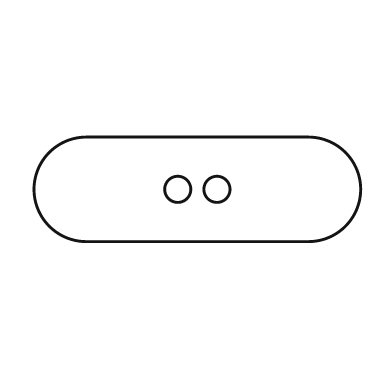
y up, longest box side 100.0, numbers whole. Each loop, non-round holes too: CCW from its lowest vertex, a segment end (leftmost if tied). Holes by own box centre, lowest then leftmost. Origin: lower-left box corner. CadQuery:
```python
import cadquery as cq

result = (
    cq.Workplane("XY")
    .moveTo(16.0, 0.0)
    .lineTo(84.0, 0.0)
    .threePointArc((100.0, 16.0), (84.0, 32.0))
    .lineTo(16.0, 32.0)
    .threePointArc((0.0, 16.0), (16.0, 0.0))
    .close()
    .moveTo(44.0, 16.0)
    .circle(4.0)
    .moveTo(56.0, 16.0)
    .circle(4.0)
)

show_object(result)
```